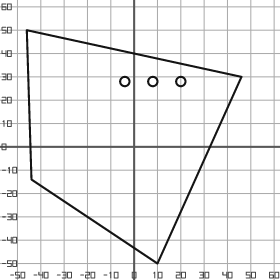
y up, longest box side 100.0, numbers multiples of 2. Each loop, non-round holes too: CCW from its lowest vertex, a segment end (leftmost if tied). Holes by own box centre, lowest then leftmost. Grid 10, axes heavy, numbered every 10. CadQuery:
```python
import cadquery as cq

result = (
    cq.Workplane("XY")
    .moveTo(10.0, -50.0)
    .lineTo(46.0, 30.0)
    .lineTo(-46.0, 50.0)
    .lineTo(-44.0, -14.0)
    .close()
    .moveTo(-4.0, 28.0)
    .circle(2.0)
    .moveTo(8.0, 28.0)
    .circle(2.0)
    .moveTo(20.0, 28.0)
    .circle(2.0)
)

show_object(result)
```